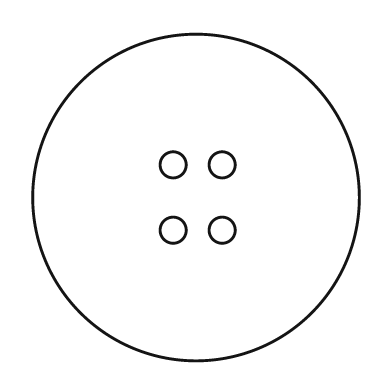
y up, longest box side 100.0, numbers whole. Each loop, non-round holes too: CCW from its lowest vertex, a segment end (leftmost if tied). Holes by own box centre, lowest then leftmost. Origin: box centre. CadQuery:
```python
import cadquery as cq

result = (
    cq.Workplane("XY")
    .moveTo(0.0, 0.0)
    .circle(50.0)
    .moveTo(-7.0, -10.0)
    .circle(4.0)
    .moveTo(8.0, -10.0)
    .circle(4.0)
    .moveTo(-7.0, 10.0)
    .circle(4.0)
    .moveTo(8.0, 10.0)
    .circle(4.0)
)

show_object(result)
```